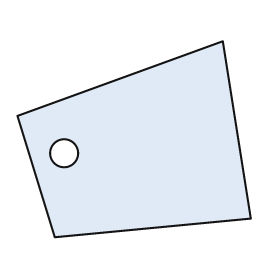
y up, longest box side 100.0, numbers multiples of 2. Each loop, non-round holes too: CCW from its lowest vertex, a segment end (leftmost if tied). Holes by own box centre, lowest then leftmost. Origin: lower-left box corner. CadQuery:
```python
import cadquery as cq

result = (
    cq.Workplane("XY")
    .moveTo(16.0, 0.0)
    .lineTo(100.0, 8.0)
    .lineTo(88.0, 84.0)
    .lineTo(0.0, 52.0)
    .close()
    .moveTo(20.0, 36.0)
    .circle(6.0)
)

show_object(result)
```